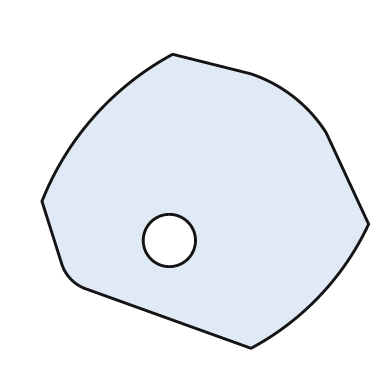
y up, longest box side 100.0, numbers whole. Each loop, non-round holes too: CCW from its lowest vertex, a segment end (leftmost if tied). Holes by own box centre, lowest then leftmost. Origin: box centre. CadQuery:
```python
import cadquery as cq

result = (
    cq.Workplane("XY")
    .moveTo(14.0, -45.0)
    .threePointArc((35.0, -29.0), (50.0, -7.0))
    .lineTo(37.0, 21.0)
    .threePointArc((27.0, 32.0), (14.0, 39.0))
    .lineTo(-10.0, 45.0)
    .threePointArc((-34.0, 26.0), (-50.0, 0.0))
    .lineTo(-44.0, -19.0)
    .threePointArc((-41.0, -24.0), (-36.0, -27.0))
    .close()
    .moveTo(-11.0, -12.0)
    .circle(8.0)
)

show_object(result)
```